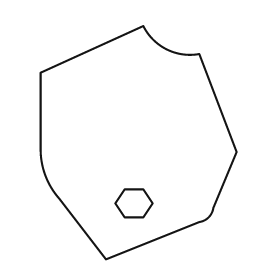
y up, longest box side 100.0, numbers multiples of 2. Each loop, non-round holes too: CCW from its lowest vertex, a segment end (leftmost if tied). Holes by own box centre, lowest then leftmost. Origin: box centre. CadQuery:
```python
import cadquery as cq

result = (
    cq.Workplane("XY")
    .moveTo(-14.0, -50.0)
    .lineTo(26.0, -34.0)
    .threePointArc((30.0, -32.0), (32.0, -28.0))
    .lineTo(42.0, -4.0)
    .lineTo(26.0, 38.0)
    .threePointArc((12.0, 40.0), (2.0, 50.0))
    .lineTo(-42.0, 30.0)
    .lineTo(-42.0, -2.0)
    .threePointArc((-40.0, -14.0), (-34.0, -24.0))
    .close()
    .moveTo(-6.0, -32.0)
    .lineTo(2.0, -32.0)
    .lineTo(6.0, -26.0)
    .lineTo(2.0, -20.0)
    .lineTo(-6.0, -20.0)
    .lineTo(-10.0, -26.0)
    .close()
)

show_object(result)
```